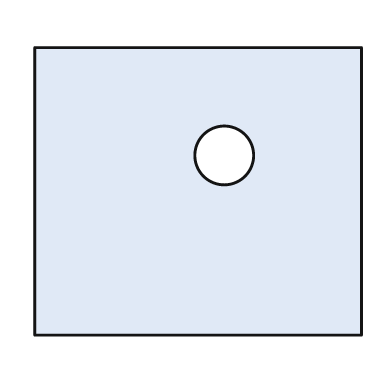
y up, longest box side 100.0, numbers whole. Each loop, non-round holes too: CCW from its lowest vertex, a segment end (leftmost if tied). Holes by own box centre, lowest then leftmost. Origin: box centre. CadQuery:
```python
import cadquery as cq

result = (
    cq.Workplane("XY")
    .moveTo(-50.0, -44.0)
    .lineTo(50.0, -44.0)
    .lineTo(50.0, 44.0)
    .lineTo(-50.0, 44.0)
    .close()
    .moveTo(8.0, 11.0)
    .circle(9.0)
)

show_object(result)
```